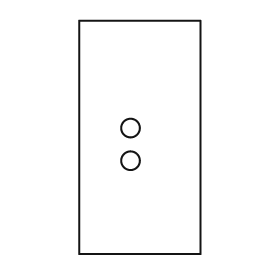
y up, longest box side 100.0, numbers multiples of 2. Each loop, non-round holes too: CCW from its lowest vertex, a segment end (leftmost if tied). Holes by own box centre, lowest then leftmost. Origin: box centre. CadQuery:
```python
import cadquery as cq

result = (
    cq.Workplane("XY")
    .moveTo(-26.0, -50.0)
    .lineTo(26.0, -50.0)
    .lineTo(26.0, 50.0)
    .lineTo(-26.0, 50.0)
    .close()
    .moveTo(-4.0, -10.0)
    .circle(4.0)
    .moveTo(-4.0, 4.0)
    .circle(4.0)
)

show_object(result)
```